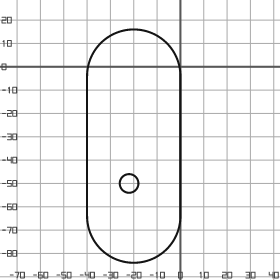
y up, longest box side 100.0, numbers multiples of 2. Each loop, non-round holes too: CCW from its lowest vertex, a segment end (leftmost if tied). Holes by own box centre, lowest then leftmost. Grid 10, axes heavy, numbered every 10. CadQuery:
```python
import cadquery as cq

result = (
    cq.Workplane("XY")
    .moveTo(-40.0, -64.0)
    .threePointArc((-20.0, -84.0), (0.0, -64.0))
    .lineTo(0.0, -4.0)
    .threePointArc((-20.0, 16.0), (-40.0, -4.0))
    .close()
    .moveTo(-22.0, -50.0)
    .circle(4.0)
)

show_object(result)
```